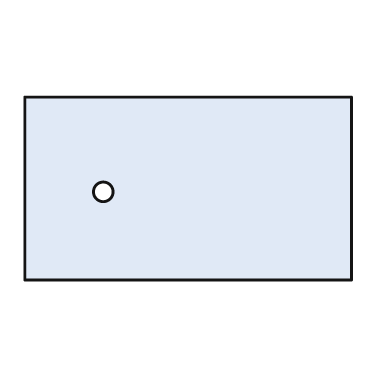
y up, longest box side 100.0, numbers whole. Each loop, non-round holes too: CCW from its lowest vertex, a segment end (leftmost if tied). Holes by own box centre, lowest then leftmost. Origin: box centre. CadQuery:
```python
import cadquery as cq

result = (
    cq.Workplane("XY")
    .moveTo(-50.0, -28.0)
    .lineTo(50.0, -28.0)
    .lineTo(50.0, 28.0)
    .lineTo(-50.0, 28.0)
    .close()
    .moveTo(-26.0, -1.0)
    .circle(3.0)
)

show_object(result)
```